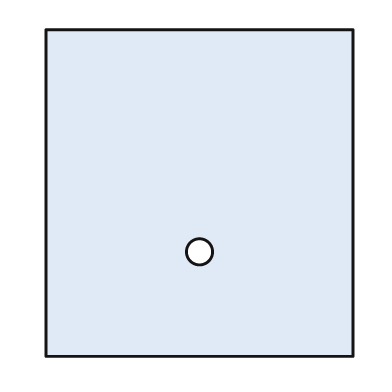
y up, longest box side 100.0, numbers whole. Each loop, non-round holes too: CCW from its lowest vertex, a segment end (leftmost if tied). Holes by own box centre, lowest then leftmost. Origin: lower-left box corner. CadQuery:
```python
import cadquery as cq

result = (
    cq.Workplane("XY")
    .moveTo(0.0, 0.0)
    .lineTo(94.0, 0.0)
    .lineTo(94.0, 100.0)
    .lineTo(0.0, 100.0)
    .close()
    .moveTo(47.0, 32.0)
    .circle(4.0)
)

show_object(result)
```